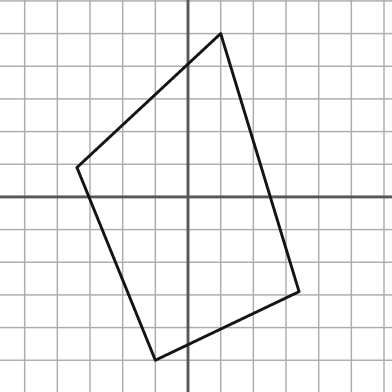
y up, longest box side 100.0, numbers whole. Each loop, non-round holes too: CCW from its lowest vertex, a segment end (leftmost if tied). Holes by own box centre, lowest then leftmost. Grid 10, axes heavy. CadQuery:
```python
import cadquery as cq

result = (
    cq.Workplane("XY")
    .moveTo(-10.0, -50.0)
    .lineTo(34.0, -29.0)
    .lineTo(10.0, 50.0)
    .lineTo(-34.0, 9.0)
    .close()
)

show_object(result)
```